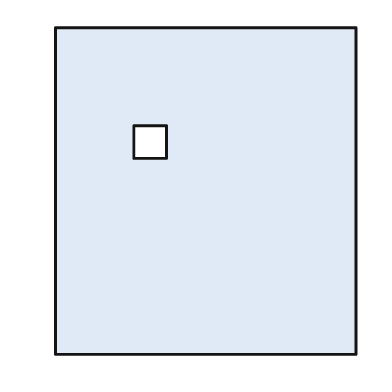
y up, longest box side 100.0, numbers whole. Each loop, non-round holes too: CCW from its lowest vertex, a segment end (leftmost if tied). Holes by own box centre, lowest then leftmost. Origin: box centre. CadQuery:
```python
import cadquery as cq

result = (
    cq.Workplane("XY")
    .moveTo(-46.0, -50.0)
    .lineTo(46.0, -50.0)
    .lineTo(46.0, 50.0)
    .lineTo(-46.0, 50.0)
    .close()
    .moveTo(-22.0, 10.0)
    .lineTo(-12.0, 10.0)
    .lineTo(-12.0, 20.0)
    .lineTo(-22.0, 20.0)
    .close()
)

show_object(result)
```